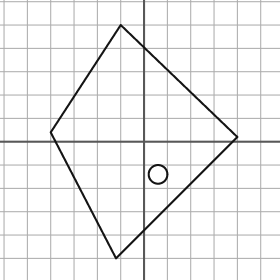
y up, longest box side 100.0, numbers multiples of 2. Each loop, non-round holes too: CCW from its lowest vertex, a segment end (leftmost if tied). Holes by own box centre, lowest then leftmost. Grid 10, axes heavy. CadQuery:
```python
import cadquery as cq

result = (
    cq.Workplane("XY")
    .moveTo(-12.0, -50.0)
    .lineTo(40.0, 2.0)
    .lineTo(-10.0, 50.0)
    .lineTo(-40.0, 4.0)
    .close()
    .moveTo(6.0, -14.0)
    .circle(4.0)
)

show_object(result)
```